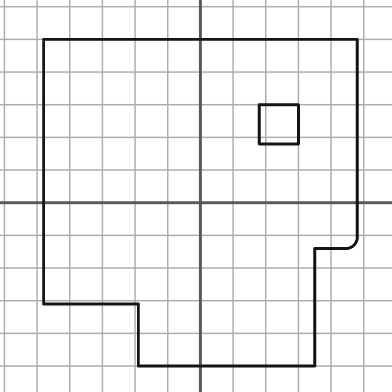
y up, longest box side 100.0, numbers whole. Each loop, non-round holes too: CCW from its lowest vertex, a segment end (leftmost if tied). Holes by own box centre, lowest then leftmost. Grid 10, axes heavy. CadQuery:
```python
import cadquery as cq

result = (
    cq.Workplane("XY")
    .moveTo(-19.0, -50.0)
    .lineTo(35.0, -50.0)
    .lineTo(35.0, -14.0)
    .lineTo(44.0, -14.0)
    .threePointArc((47.0, -13.0), (48.0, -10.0))
    .lineTo(48.0, 50.0)
    .lineTo(-48.0, 50.0)
    .lineTo(-48.0, -31.0)
    .lineTo(-19.0, -31.0)
    .close()
    .moveTo(18.0, 18.0)
    .lineTo(30.0, 18.0)
    .lineTo(30.0, 30.0)
    .lineTo(18.0, 30.0)
    .close()
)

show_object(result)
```